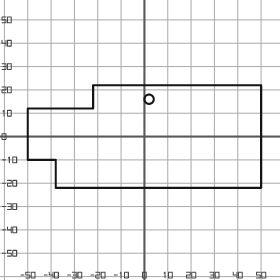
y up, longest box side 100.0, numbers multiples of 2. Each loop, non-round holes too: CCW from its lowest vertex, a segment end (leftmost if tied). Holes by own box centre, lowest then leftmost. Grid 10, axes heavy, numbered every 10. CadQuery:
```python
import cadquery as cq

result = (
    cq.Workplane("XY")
    .moveTo(-38.0, -22.0)
    .lineTo(50.0, -22.0)
    .lineTo(50.0, 22.0)
    .lineTo(-22.0, 22.0)
    .lineTo(-22.0, 12.0)
    .lineTo(-50.0, 12.0)
    .lineTo(-50.0, -10.0)
    .lineTo(-38.0, -10.0)
    .close()
    .moveTo(2.0, 16.0)
    .circle(2.0)
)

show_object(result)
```